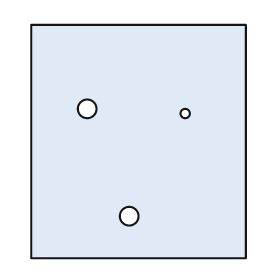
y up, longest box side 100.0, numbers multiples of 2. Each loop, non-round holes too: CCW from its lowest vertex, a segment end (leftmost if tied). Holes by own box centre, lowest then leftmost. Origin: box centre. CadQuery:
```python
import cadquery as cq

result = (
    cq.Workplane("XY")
    .moveTo(-46.0, -50.0)
    .lineTo(46.0, -50.0)
    .lineTo(46.0, 50.0)
    .lineTo(-46.0, 50.0)
    .close()
    .moveTo(-4.0, -32.0)
    .circle(4.0)
    .moveTo(20.0, 12.0)
    .circle(2.0)
    .moveTo(-22.0, 14.0)
    .circle(4.0)
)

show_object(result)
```